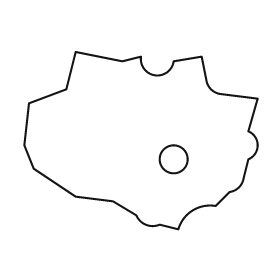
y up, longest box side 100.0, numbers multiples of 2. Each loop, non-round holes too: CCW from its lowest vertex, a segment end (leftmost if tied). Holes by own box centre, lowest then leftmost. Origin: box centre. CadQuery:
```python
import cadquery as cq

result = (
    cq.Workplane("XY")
    .moveTo(16.0, -38.0)
    .threePointArc((22.0, -30.0), (32.0, -28.0))
    .lineTo(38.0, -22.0)
    .threePointArc((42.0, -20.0), (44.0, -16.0))
    .lineTo(46.0, -8.0)
    .threePointArc((50.0, -2.0), (46.0, 4.0))
    .lineTo(50.0, 18.0)
    .lineTo(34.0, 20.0)
    .threePointArc((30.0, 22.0), (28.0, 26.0))
    .lineTo(26.0, 36.0)
    .lineTo(14.0, 34.0)
    .threePointArc((6.0, 28.0), (0.0, 36.0))
    .lineTo(-8.0, 34.0)
    .lineTo(-28.0, 38.0)
    .lineTo(-32.0, 22.0)
    .lineTo(-48.0, 16.0)
    .lineTo(-50.0, -2.0)
    .lineTo(-46.0, -12.0)
    .lineTo(-28.0, -24.0)
    .lineTo(-12.0, -26.0)
    .lineTo(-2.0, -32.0)
    .threePointArc((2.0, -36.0), (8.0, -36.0))
    .close()
    .moveTo(14.0, -8.0)
    .circle(6.0)
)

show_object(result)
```